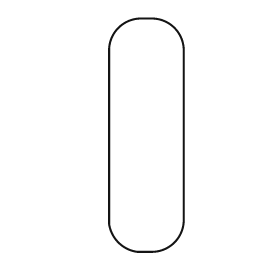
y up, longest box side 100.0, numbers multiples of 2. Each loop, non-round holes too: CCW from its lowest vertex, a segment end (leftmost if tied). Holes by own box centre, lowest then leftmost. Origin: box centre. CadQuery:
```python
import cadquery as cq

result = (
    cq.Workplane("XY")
    .moveTo(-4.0, -50.0)
    .lineTo(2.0, -50.0)
    .threePointArc((12.0, -46.0), (16.0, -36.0))
    .lineTo(16.0, 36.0)
    .threePointArc((12.0, 46.0), (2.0, 50.0))
    .lineTo(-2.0, 50.0)
    .threePointArc((-12.0, 46.0), (-16.0, 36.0))
    .lineTo(-16.0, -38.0)
    .threePointArc((-12.0, -46.0), (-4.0, -50.0))
    .close()
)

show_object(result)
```